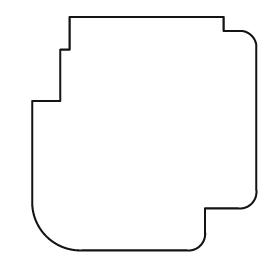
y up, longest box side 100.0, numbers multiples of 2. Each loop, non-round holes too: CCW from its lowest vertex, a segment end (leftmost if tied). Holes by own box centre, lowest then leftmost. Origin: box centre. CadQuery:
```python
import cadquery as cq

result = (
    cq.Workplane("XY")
    .moveTo(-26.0, -50.0)
    .lineTo(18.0, -50.0)
    .threePointArc((24.0, -48.0), (26.0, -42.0))
    .lineTo(26.0, -32.0)
    .lineTo(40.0, -32.0)
    .threePointArc((46.0, -30.0), (48.0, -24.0))
    .lineTo(48.0, 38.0)
    .threePointArc((46.0, 42.0), (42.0, 44.0))
    .lineTo(34.0, 44.0)
    .lineTo(34.0, 50.0)
    .lineTo(-32.0, 50.0)
    .lineTo(-32.0, 36.0)
    .lineTo(-36.0, 36.0)
    .lineTo(-36.0, 14.0)
    .lineTo(-48.0, 14.0)
    .lineTo(-48.0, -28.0)
    .threePointArc((-42.0, -44.0), (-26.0, -50.0))
    .close()
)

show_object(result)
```